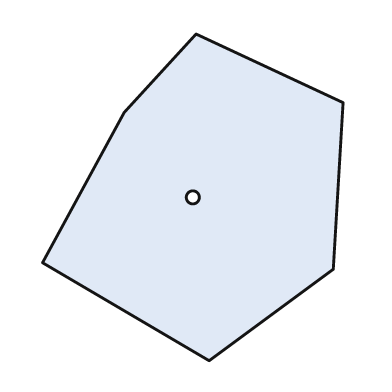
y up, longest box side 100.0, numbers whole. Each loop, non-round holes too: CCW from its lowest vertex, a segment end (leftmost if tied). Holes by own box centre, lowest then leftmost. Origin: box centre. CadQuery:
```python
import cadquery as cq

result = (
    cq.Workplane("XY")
    .moveTo(5.0, -50.0)
    .lineTo(43.0, -22.0)
    .lineTo(46.0, 29.0)
    .lineTo(1.0, 50.0)
    .lineTo(-21.0, 26.0)
    .lineTo(-46.0, -20.0)
    .close()
    .moveTo(0.0, 0.0)
    .circle(2.0)
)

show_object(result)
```